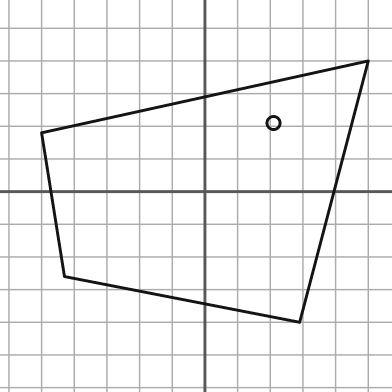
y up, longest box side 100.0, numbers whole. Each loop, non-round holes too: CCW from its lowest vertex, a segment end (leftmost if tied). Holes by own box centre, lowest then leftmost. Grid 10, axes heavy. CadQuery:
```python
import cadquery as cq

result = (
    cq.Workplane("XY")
    .moveTo(29.0, -40.0)
    .lineTo(50.0, 40.0)
    .lineTo(-50.0, 18.0)
    .lineTo(-43.0, -26.0)
    .close()
    .moveTo(21.0, 21.0)
    .circle(2.0)
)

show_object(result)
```